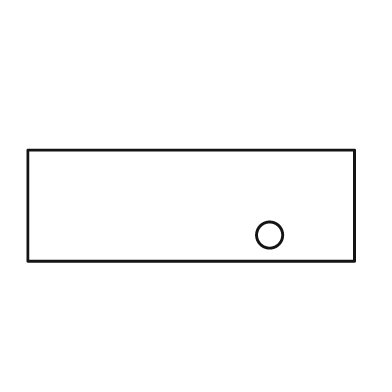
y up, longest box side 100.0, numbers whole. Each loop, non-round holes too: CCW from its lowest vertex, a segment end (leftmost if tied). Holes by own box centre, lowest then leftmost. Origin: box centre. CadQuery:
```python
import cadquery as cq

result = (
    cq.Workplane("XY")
    .moveTo(-50.0, -17.0)
    .lineTo(50.0, -17.0)
    .lineTo(50.0, 17.0)
    .lineTo(-50.0, 17.0)
    .close()
    .moveTo(24.0, -9.0)
    .circle(4.0)
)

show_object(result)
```